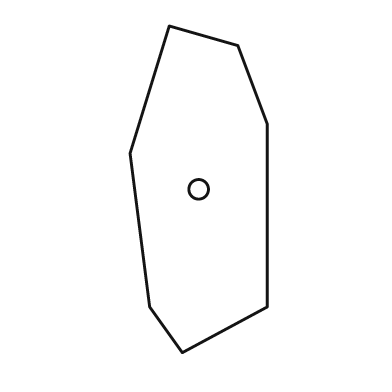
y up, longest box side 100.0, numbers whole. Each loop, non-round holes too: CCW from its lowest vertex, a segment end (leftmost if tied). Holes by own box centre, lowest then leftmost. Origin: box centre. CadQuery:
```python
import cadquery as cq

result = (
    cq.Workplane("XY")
    .moveTo(-5.0, -50.0)
    .lineTo(21.0, -36.0)
    .lineTo(21.0, 20.0)
    .lineTo(12.0, 44.0)
    .lineTo(-9.0, 50.0)
    .lineTo(-21.0, 11.0)
    .lineTo(-15.0, -36.0)
    .close()
    .moveTo(0.0, 0.0)
    .circle(3.0)
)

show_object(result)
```